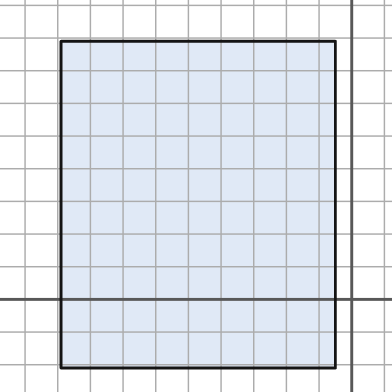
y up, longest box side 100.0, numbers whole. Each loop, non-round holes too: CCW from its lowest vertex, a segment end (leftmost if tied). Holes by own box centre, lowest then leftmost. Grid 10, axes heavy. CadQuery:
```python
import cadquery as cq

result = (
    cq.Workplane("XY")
    .moveTo(-89.0, -21.0)
    .lineTo(-5.0, -21.0)
    .lineTo(-5.0, 79.0)
    .lineTo(-89.0, 79.0)
    .close()
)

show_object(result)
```